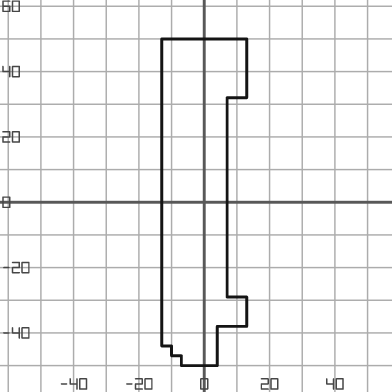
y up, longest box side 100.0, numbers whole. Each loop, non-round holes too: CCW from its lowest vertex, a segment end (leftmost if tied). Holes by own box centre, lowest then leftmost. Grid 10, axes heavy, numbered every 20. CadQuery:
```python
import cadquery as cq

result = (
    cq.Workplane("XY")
    .moveTo(-7.0, -50.0)
    .lineTo(4.0, -50.0)
    .lineTo(4.0, -38.0)
    .lineTo(13.0, -38.0)
    .lineTo(13.0, -29.0)
    .lineTo(7.0, -29.0)
    .lineTo(7.0, 32.0)
    .lineTo(13.0, 32.0)
    .lineTo(13.0, 50.0)
    .lineTo(-13.0, 50.0)
    .lineTo(-13.0, -44.0)
    .lineTo(-10.0, -44.0)
    .lineTo(-10.0, -47.0)
    .lineTo(-7.0, -47.0)
    .close()
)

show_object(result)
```